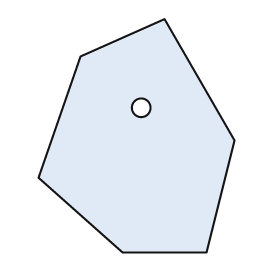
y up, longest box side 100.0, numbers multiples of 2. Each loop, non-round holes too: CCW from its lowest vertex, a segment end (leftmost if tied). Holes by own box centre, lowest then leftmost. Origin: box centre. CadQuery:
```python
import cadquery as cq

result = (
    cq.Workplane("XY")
    .moveTo(-6.0, -50.0)
    .lineTo(30.0, -50.0)
    .lineTo(42.0, -2.0)
    .lineTo(12.0, 50.0)
    .lineTo(-24.0, 34.0)
    .lineTo(-42.0, -18.0)
    .close()
    .moveTo(2.0, 12.0)
    .circle(4.0)
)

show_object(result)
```